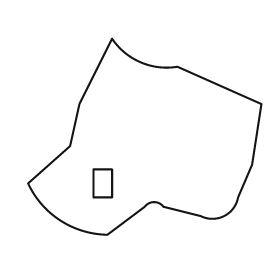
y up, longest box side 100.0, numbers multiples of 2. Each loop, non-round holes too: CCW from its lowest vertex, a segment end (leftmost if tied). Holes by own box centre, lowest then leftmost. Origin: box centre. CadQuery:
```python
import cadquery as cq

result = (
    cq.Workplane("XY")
    .moveTo(-16.0, -42.0)
    .lineTo(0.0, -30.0)
    .threePointArc((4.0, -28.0), (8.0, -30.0))
    .lineTo(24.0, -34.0)
    .threePointArc((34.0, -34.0), (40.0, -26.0))
    .lineTo(46.0, -12.0)
    .lineTo(50.0, 14.0)
    .lineTo(14.0, 30.0)
    .threePointArc((-2.0, 32.0), (-14.0, 42.0))
    .lineTo(-28.0, 14.0)
    .lineTo(-32.0, -4.0)
    .lineTo(-50.0, -20.0)
    .threePointArc((-36.0, -36.0), (-16.0, -42.0))
    .close()
    .moveTo(-22.0, -26.0)
    .lineTo(-14.0, -26.0)
    .lineTo(-14.0, -14.0)
    .lineTo(-22.0, -14.0)
    .close()
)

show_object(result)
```